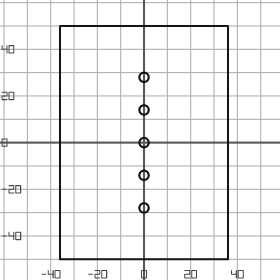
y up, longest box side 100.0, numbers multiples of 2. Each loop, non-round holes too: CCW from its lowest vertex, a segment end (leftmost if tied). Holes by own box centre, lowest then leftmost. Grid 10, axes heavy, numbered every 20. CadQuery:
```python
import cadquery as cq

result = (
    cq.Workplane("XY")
    .moveTo(-36.0, -50.0)
    .lineTo(36.0, -50.0)
    .lineTo(36.0, 50.0)
    .lineTo(-36.0, 50.0)
    .close()
    .moveTo(0.0, -28.0)
    .circle(2.0)
    .moveTo(0.0, -14.0)
    .circle(2.0)
    .moveTo(0.0, 0.0)
    .circle(2.0)
    .moveTo(0.0, 14.0)
    .circle(2.0)
    .moveTo(0.0, 28.0)
    .circle(2.0)
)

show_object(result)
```